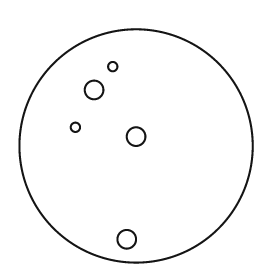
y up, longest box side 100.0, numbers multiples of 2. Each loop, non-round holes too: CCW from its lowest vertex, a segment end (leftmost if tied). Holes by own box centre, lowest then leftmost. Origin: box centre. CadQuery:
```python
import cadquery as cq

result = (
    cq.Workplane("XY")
    .moveTo(0.0, 0.0)
    .circle(50.0)
    .moveTo(-4.0, -40.0)
    .circle(4.0)
    .moveTo(0.0, 4.0)
    .circle(4.0)
    .moveTo(-26.0, 8.0)
    .circle(2.0)
    .moveTo(-18.0, 24.0)
    .circle(4.0)
    .moveTo(-10.0, 34.0)
    .circle(2.0)
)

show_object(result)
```